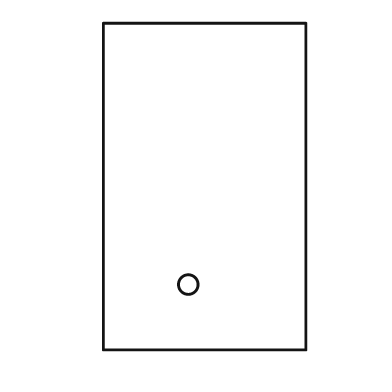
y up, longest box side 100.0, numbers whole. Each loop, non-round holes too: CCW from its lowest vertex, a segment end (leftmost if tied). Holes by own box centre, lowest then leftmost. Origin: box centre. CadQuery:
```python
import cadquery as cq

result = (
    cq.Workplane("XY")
    .moveTo(-31.0, -50.0)
    .lineTo(31.0, -50.0)
    .lineTo(31.0, 50.0)
    .lineTo(-31.0, 50.0)
    .close()
    .moveTo(-5.0, -30.0)
    .circle(3.0)
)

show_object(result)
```